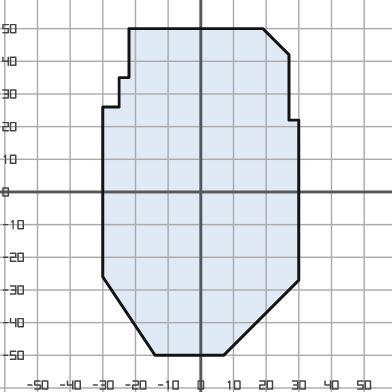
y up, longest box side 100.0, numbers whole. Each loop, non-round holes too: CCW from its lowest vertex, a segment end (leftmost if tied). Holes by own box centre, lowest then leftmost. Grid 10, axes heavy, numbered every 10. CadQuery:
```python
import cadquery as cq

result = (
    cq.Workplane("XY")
    .moveTo(-14.0, -50.0)
    .lineTo(7.0, -50.0)
    .lineTo(30.0, -27.0)
    .lineTo(30.0, 22.0)
    .lineTo(27.0, 22.0)
    .lineTo(27.0, 42.0)
    .lineTo(19.0, 50.0)
    .lineTo(-22.0, 50.0)
    .lineTo(-22.0, 35.0)
    .lineTo(-25.0, 35.0)
    .lineTo(-25.0, 26.0)
    .lineTo(-30.0, 26.0)
    .lineTo(-30.0, -26.0)
    .close()
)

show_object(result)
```